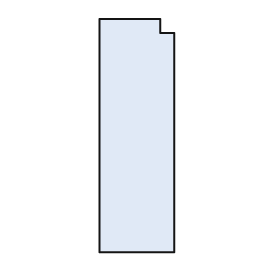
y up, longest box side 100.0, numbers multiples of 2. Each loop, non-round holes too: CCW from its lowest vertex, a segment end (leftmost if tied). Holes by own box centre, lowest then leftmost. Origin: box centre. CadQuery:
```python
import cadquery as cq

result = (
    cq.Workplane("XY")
    .moveTo(-16.0, -50.0)
    .lineTo(16.0, -50.0)
    .lineTo(16.0, 44.0)
    .lineTo(10.0, 44.0)
    .lineTo(10.0, 50.0)
    .lineTo(-16.0, 50.0)
    .close()
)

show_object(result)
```